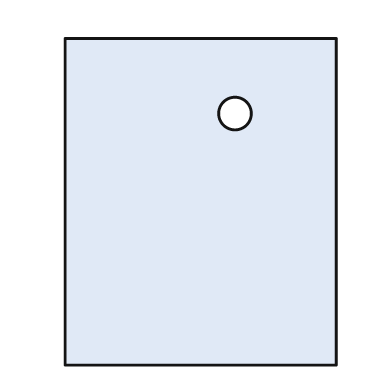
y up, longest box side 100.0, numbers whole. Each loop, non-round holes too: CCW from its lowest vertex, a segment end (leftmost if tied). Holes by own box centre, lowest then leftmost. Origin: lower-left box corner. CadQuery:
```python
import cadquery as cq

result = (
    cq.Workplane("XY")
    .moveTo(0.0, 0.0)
    .lineTo(83.0, 0.0)
    .lineTo(83.0, 100.0)
    .lineTo(0.0, 100.0)
    .close()
    .moveTo(52.0, 77.0)
    .circle(5.0)
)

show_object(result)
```